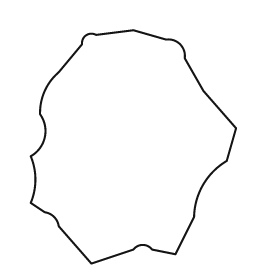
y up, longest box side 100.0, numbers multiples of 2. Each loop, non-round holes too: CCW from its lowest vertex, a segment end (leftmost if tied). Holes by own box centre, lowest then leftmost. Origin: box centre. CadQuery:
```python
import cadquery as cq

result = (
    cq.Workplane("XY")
    .moveTo(-18.0, -50.0)
    .lineTo(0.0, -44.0)
    .threePointArc((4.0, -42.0), (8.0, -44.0))
    .lineTo(18.0, -46.0)
    .lineTo(26.0, -30.0)
    .threePointArc((30.0, -16.0), (40.0, -6.0))
    .lineTo(44.0, 8.0)
    .lineTo(30.0, 24.0)
    .lineTo(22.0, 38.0)
    .threePointArc((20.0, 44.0), (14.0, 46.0))
    .lineTo(0.0, 50.0)
    .lineTo(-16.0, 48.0)
    .threePointArc((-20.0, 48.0), (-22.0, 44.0))
    .lineTo(-32.0, 32.0)
    .threePointArc((-38.0, 24.0), (-40.0, 14.0))
    .threePointArc((-38.0, 4.0), (-44.0, -4.0))
    .threePointArc((-42.0, -14.0), (-44.0, -24.0))
    .lineTo(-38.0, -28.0)
    .threePointArc((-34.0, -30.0), (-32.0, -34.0))
    .close()
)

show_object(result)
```